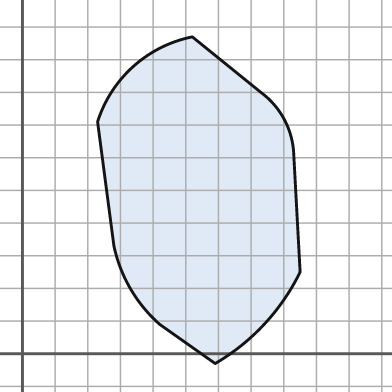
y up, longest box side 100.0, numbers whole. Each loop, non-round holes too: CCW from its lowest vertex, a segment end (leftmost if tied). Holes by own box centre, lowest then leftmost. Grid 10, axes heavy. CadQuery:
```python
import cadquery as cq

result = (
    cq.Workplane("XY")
    .moveTo(59.0, -3.0)
    .threePointArc((74.0, 9.0), (85.0, 25.0))
    .lineTo(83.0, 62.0)
    .threePointArc((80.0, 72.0), (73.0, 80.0))
    .lineTo(52.0, 97.0)
    .threePointArc((34.0, 88.0), (23.0, 71.0))
    .lineTo(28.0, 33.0)
    .threePointArc((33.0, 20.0), (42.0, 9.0))
    .close()
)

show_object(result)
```